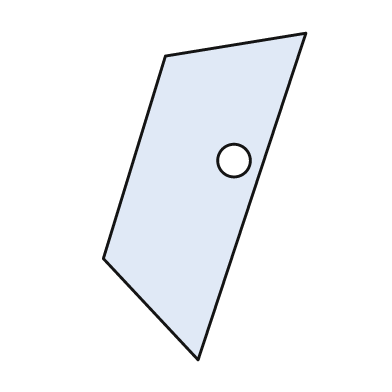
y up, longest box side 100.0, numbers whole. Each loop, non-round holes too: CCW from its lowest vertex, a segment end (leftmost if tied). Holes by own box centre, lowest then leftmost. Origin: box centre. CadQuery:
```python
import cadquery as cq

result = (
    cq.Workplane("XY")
    .moveTo(-2.0, -50.0)
    .lineTo(31.0, 50.0)
    .lineTo(-12.0, 43.0)
    .lineTo(-31.0, -19.0)
    .close()
    .moveTo(9.0, 11.0)
    .circle(5.0)
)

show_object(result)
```